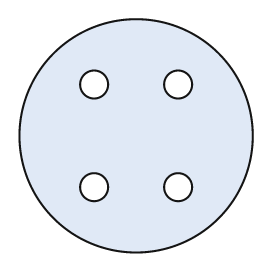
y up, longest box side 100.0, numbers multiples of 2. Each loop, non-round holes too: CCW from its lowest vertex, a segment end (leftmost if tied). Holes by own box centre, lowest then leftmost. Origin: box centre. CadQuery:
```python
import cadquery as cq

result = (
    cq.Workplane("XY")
    .moveTo(0.0, 0.0)
    .circle(50.0)
    .moveTo(-18.0, -22.0)
    .circle(6.0)
    .moveTo(18.0, -22.0)
    .circle(6.0)
    .moveTo(-18.0, 22.0)
    .circle(6.0)
    .moveTo(18.0, 22.0)
    .circle(6.0)
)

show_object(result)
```